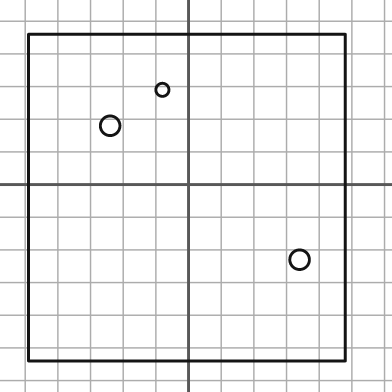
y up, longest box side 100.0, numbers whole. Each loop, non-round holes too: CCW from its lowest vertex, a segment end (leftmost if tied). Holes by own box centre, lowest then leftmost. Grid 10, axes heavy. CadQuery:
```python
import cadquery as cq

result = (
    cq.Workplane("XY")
    .moveTo(-49.0, -54.0)
    .lineTo(48.0, -54.0)
    .lineTo(48.0, 46.0)
    .lineTo(-49.0, 46.0)
    .close()
    .moveTo(34.0, -23.0)
    .circle(3.0)
    .moveTo(-24.0, 18.0)
    .circle(3.0)
    .moveTo(-8.0, 29.0)
    .circle(2.0)
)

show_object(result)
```